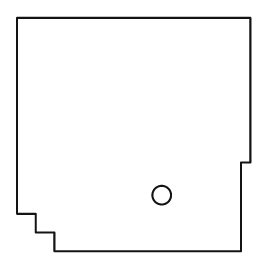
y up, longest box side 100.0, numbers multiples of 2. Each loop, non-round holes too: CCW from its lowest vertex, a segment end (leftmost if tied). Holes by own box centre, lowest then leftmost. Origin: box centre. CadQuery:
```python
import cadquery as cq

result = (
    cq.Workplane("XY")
    .moveTo(-34.0, -50.0)
    .lineTo(46.0, -50.0)
    .lineTo(46.0, -12.0)
    .lineTo(50.0, -12.0)
    .lineTo(50.0, 50.0)
    .lineTo(-50.0, 50.0)
    .lineTo(-50.0, -34.0)
    .lineTo(-42.0, -34.0)
    .lineTo(-42.0, -42.0)
    .lineTo(-34.0, -42.0)
    .close()
    .moveTo(12.0, -26.0)
    .circle(4.0)
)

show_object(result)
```